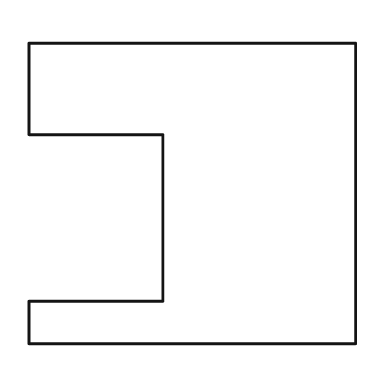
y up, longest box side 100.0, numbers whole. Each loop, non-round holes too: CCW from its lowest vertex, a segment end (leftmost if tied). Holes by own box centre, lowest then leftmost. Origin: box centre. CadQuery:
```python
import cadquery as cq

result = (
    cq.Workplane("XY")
    .moveTo(-50.0, -46.0)
    .lineTo(50.0, -46.0)
    .lineTo(50.0, 46.0)
    .lineTo(-50.0, 46.0)
    .lineTo(-50.0, 18.0)
    .lineTo(-9.0, 18.0)
    .lineTo(-9.0, -33.0)
    .lineTo(-50.0, -33.0)
    .close()
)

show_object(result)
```